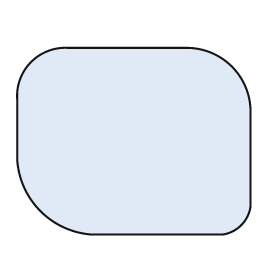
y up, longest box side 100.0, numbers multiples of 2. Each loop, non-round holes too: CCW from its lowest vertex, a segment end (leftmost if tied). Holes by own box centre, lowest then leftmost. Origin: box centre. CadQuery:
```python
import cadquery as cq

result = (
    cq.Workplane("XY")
    .moveTo(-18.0, -40.0)
    .lineTo(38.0, -40.0)
    .threePointArc((46.0, -36.0), (50.0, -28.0))
    .lineTo(50.0, 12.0)
    .threePointArc((42.0, 32.0), (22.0, 40.0))
    .lineTo(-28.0, 40.0)
    .threePointArc((-44.0, 34.0), (-50.0, 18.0))
    .lineTo(-50.0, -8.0)
    .threePointArc((-40.0, -30.0), (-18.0, -40.0))
    .close()
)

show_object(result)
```